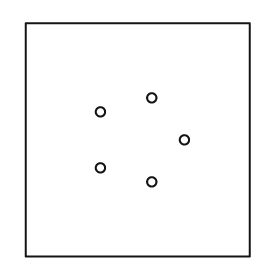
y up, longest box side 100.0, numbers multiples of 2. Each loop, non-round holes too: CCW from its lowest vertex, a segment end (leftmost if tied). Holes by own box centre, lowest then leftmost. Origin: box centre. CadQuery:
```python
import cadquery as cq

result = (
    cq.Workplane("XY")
    .moveTo(-48.0, -50.0)
    .lineTo(48.0, -50.0)
    .lineTo(48.0, 50.0)
    .lineTo(-48.0, 50.0)
    .close()
    .moveTo(6.0, -18.0)
    .circle(2.0)
    .moveTo(-16.0, -12.0)
    .circle(2.0)
    .moveTo(20.0, 0.0)
    .circle(2.0)
    .moveTo(-16.0, 12.0)
    .circle(2.0)
    .moveTo(6.0, 18.0)
    .circle(2.0)
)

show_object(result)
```